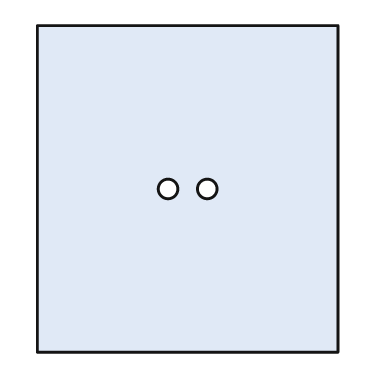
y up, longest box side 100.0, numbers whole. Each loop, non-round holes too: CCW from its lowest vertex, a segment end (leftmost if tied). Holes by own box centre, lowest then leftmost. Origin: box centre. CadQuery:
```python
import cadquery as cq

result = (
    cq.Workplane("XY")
    .moveTo(-46.0, -50.0)
    .lineTo(46.0, -50.0)
    .lineTo(46.0, 50.0)
    .lineTo(-46.0, 50.0)
    .close()
    .moveTo(-6.0, 0.0)
    .circle(3.0)
    .moveTo(6.0, 0.0)
    .circle(3.0)
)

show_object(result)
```